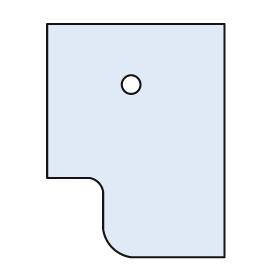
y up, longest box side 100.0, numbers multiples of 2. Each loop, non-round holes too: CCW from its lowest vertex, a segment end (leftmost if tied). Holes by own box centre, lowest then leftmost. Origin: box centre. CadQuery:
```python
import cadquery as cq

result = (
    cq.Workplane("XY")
    .moveTo(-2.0, -50.0)
    .lineTo(38.0, -50.0)
    .lineTo(38.0, 50.0)
    .lineTo(-38.0, 50.0)
    .lineTo(-38.0, -16.0)
    .lineTo(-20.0, -16.0)
    .threePointArc((-16.0, -18.0), (-14.0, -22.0))
    .lineTo(-14.0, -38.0)
    .threePointArc((-10.0, -46.0), (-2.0, -50.0))
    .close()
    .moveTo(-2.0, 24.0)
    .circle(4.0)
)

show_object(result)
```